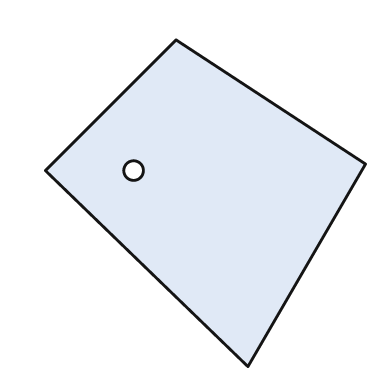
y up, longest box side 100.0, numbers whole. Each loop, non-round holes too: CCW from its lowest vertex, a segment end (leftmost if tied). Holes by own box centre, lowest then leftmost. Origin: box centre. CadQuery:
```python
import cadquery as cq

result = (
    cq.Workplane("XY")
    .moveTo(13.0, -50.0)
    .lineTo(49.0, 12.0)
    .lineTo(-9.0, 50.0)
    .lineTo(-49.0, 10.0)
    .close()
    .moveTo(-22.0, 10.0)
    .circle(3.0)
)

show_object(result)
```